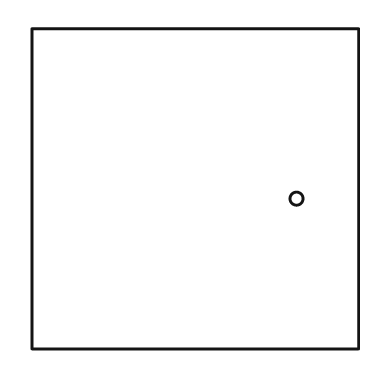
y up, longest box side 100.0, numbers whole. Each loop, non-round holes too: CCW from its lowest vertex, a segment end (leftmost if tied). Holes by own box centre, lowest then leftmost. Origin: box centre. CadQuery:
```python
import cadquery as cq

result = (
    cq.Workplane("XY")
    .moveTo(-50.0, -49.0)
    .lineTo(50.0, -49.0)
    .lineTo(50.0, 49.0)
    .lineTo(-50.0, 49.0)
    .close()
    .moveTo(31.0, -3.0)
    .circle(2.0)
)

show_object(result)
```